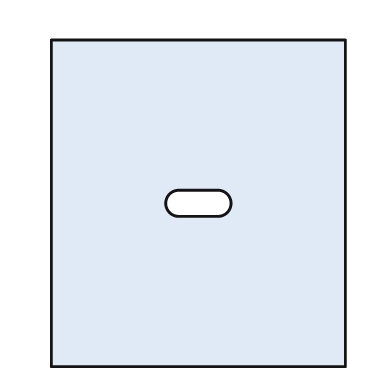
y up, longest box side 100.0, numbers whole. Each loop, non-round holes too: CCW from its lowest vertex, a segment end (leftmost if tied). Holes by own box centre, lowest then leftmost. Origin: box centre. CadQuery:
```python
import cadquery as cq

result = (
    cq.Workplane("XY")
    .moveTo(-45.0, -50.0)
    .lineTo(45.0, -50.0)
    .lineTo(45.0, 50.0)
    .lineTo(-45.0, 50.0)
    .close()
    .moveTo(-6.0, -4.0)
    .lineTo(6.0, -4.0)
    .threePointArc((10.0, 0.0), (6.0, 4.0))
    .lineTo(-6.0, 4.0)
    .threePointArc((-10.0, 0.0), (-6.0, -4.0))
    .close()
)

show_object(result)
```